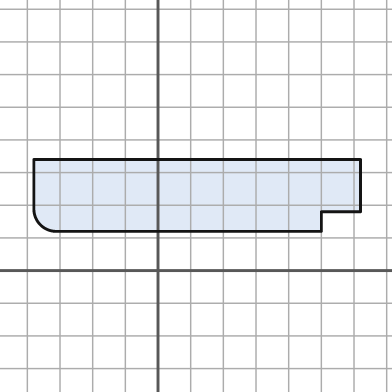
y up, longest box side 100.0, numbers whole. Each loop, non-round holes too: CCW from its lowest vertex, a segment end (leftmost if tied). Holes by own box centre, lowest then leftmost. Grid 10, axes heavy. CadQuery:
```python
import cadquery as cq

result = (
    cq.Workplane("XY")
    .moveTo(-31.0, 12.0)
    .lineTo(50.0, 12.0)
    .lineTo(50.0, 18.0)
    .lineTo(62.0, 18.0)
    .lineTo(62.0, 34.0)
    .lineTo(-38.0, 34.0)
    .lineTo(-38.0, 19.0)
    .threePointArc((-36.0, 14.0), (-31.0, 12.0))
    .close()
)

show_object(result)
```